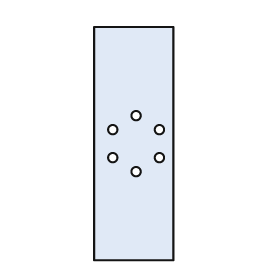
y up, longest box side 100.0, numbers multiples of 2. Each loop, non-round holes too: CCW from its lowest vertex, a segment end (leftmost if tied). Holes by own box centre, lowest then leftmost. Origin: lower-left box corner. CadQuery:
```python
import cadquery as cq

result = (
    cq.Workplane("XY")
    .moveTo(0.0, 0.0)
    .lineTo(34.0, 0.0)
    .lineTo(34.0, 100.0)
    .lineTo(0.0, 100.0)
    .close()
    .moveTo(18.0, 38.0)
    .circle(2.0)
    .moveTo(8.0, 44.0)
    .circle(2.0)
    .moveTo(28.0, 44.0)
    .circle(2.0)
    .moveTo(8.0, 56.0)
    .circle(2.0)
    .moveTo(28.0, 56.0)
    .circle(2.0)
    .moveTo(18.0, 62.0)
    .circle(2.0)
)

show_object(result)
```